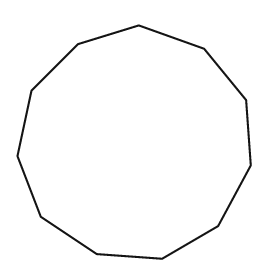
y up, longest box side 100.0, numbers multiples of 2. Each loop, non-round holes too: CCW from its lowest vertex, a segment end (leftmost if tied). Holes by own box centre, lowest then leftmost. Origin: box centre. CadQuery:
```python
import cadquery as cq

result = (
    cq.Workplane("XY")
    .moveTo(12.0, -50.0)
    .lineTo(36.0, -36.0)
    .lineTo(50.0, -10.0)
    .lineTo(48.0, 18.0)
    .lineTo(30.0, 40.0)
    .lineTo(2.0, 50.0)
    .lineTo(-24.0, 42.0)
    .lineTo(-44.0, 22.0)
    .lineTo(-50.0, -6.0)
    .lineTo(-40.0, -32.0)
    .lineTo(-16.0, -48.0)
    .close()
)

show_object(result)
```